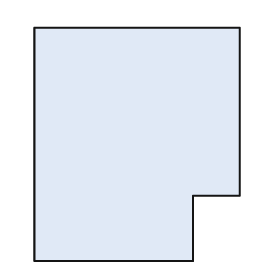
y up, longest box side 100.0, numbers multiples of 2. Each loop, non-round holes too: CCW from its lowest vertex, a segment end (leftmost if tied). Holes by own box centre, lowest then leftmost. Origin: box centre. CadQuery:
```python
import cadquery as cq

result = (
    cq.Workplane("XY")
    .moveTo(-44.0, -50.0)
    .lineTo(24.0, -50.0)
    .lineTo(24.0, -22.0)
    .lineTo(44.0, -22.0)
    .lineTo(44.0, 50.0)
    .lineTo(-44.0, 50.0)
    .close()
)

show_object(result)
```